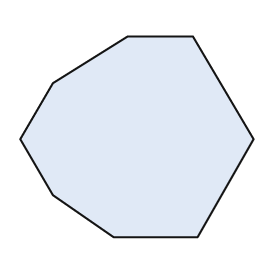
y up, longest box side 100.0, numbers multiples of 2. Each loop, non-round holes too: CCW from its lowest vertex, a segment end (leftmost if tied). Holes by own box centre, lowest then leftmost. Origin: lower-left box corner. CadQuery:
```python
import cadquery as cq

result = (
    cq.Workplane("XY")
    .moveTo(40.0, 0.0)
    .lineTo(76.0, 0.0)
    .lineTo(100.0, 42.0)
    .lineTo(74.0, 86.0)
    .lineTo(46.0, 86.0)
    .lineTo(14.0, 66.0)
    .lineTo(0.0, 42.0)
    .lineTo(14.0, 18.0)
    .close()
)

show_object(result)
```